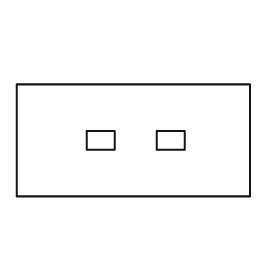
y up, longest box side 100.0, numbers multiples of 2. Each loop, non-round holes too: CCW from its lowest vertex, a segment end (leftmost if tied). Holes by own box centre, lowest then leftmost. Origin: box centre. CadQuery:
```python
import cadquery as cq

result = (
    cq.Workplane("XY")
    .moveTo(-50.0, -24.0)
    .lineTo(50.0, -24.0)
    .lineTo(50.0, 24.0)
    .lineTo(-50.0, 24.0)
    .close()
    .moveTo(-20.0, -4.0)
    .lineTo(-8.0, -4.0)
    .lineTo(-8.0, 4.0)
    .lineTo(-20.0, 4.0)
    .close()
    .moveTo(10.0, -4.0)
    .lineTo(22.0, -4.0)
    .lineTo(22.0, 4.0)
    .lineTo(10.0, 4.0)
    .close()
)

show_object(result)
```